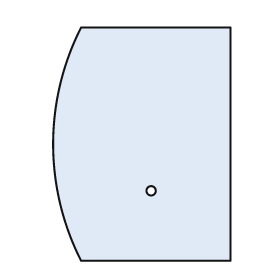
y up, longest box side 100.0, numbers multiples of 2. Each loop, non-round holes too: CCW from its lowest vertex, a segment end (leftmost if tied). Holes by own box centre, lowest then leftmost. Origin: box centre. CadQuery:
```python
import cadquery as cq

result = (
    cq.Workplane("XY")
    .moveTo(-26.0, -50.0)
    .lineTo(38.0, -50.0)
    .lineTo(38.0, 50.0)
    .lineTo(-26.0, 50.0)
    .threePointArc((-38.0, 0.0), (-26.0, -50.0))
    .close()
    .moveTo(4.0, -20.0)
    .circle(2.0)
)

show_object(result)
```